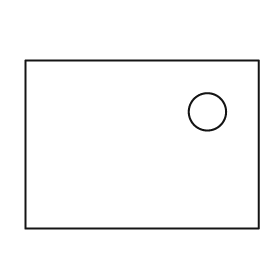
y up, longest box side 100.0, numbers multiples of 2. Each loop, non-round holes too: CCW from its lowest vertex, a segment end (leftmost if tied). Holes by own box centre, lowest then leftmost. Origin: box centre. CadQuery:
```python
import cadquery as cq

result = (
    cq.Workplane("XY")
    .moveTo(-50.0, -36.0)
    .lineTo(50.0, -36.0)
    .lineTo(50.0, 36.0)
    .lineTo(-50.0, 36.0)
    .close()
    .moveTo(28.0, 14.0)
    .circle(8.0)
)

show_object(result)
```